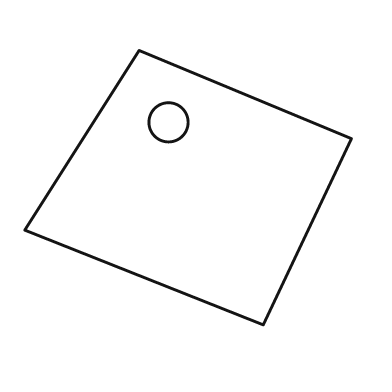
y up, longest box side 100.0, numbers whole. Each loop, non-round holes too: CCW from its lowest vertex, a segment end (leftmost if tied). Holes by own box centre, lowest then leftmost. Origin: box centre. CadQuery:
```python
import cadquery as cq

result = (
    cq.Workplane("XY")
    .moveTo(23.0, -42.0)
    .lineTo(50.0, 15.0)
    .lineTo(-15.0, 42.0)
    .lineTo(-50.0, -13.0)
    .close()
    .moveTo(-6.0, 20.0)
    .circle(6.0)
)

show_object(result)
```